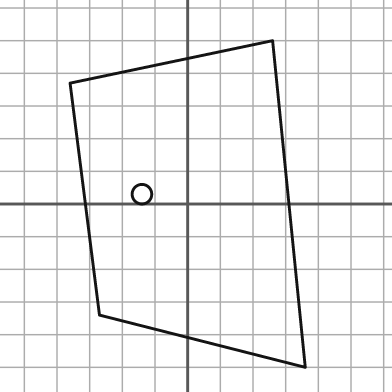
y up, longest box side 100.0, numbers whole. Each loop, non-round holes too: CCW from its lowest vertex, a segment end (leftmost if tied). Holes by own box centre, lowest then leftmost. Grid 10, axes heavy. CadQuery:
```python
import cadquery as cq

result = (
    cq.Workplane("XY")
    .moveTo(36.0, -50.0)
    .lineTo(26.0, 50.0)
    .lineTo(-36.0, 37.0)
    .lineTo(-27.0, -34.0)
    .close()
    .moveTo(-14.0, 3.0)
    .circle(3.0)
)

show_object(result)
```